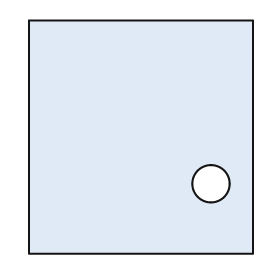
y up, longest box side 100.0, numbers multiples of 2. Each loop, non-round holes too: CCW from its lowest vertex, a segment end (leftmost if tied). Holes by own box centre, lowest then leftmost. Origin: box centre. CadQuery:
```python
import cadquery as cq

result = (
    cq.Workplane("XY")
    .moveTo(-48.0, -50.0)
    .lineTo(48.0, -50.0)
    .lineTo(48.0, 50.0)
    .lineTo(-48.0, 50.0)
    .close()
    .moveTo(30.0, -20.0)
    .circle(8.0)
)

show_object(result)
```